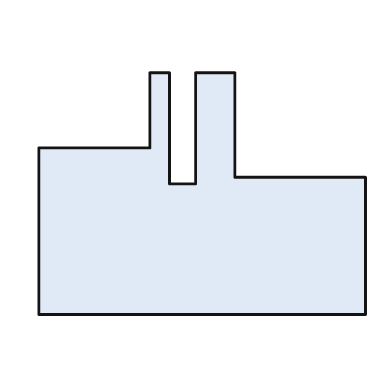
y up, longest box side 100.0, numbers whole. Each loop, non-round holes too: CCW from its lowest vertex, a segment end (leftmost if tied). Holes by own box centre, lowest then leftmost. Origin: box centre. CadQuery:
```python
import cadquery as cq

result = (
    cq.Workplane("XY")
    .moveTo(-50.0, -37.0)
    .lineTo(50.0, -37.0)
    .lineTo(50.0, 5.0)
    .lineTo(10.0, 5.0)
    .lineTo(10.0, 37.0)
    .lineTo(-2.0, 37.0)
    .lineTo(-2.0, 3.0)
    .lineTo(-10.0, 3.0)
    .lineTo(-10.0, 37.0)
    .lineTo(-16.0, 37.0)
    .lineTo(-16.0, 14.0)
    .lineTo(-50.0, 14.0)
    .close()
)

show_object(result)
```